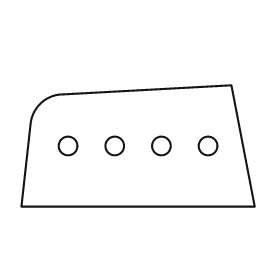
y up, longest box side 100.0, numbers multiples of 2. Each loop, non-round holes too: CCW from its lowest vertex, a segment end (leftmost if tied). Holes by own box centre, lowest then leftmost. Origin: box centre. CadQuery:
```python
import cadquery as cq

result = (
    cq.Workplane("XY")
    .moveTo(-50.0, -26.0)
    .lineTo(50.0, -26.0)
    .lineTo(40.0, 26.0)
    .lineTo(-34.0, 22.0)
    .threePointArc((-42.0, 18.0), (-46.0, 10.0))
    .close()
    .moveTo(-30.0, 0.0)
    .circle(4.0)
    .moveTo(-10.0, 0.0)
    .circle(4.0)
    .moveTo(10.0, 0.0)
    .circle(4.0)
    .moveTo(30.0, 0.0)
    .circle(4.0)
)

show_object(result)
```